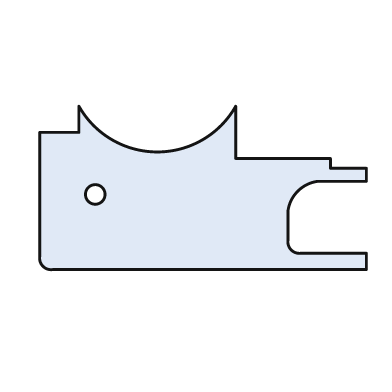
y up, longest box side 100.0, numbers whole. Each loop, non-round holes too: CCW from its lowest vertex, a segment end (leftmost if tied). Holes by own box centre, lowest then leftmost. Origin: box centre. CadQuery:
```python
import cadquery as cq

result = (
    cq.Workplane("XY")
    .moveTo(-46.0, -25.0)
    .lineTo(50.0, -25.0)
    .lineTo(50.0, -20.0)
    .lineTo(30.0, -20.0)
    .threePointArc((27.0, -19.0), (26.0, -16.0))
    .lineTo(26.0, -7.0)
    .threePointArc((29.0, -1.0), (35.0, 2.0))
    .lineTo(50.0, 2.0)
    .lineTo(50.0, 6.0)
    .lineTo(39.0, 6.0)
    .lineTo(39.0, 9.0)
    .lineTo(10.0, 9.0)
    .lineTo(10.0, 25.0)
    .threePointArc((-14.0, 11.0), (-38.0, 25.0))
    .lineTo(-38.0, 17.0)
    .lineTo(-50.0, 17.0)
    .lineTo(-50.0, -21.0)
    .threePointArc((-49.0, -24.0), (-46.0, -25.0))
    .close()
    .moveTo(-33.0, -2.0)
    .circle(3.0)
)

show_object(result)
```